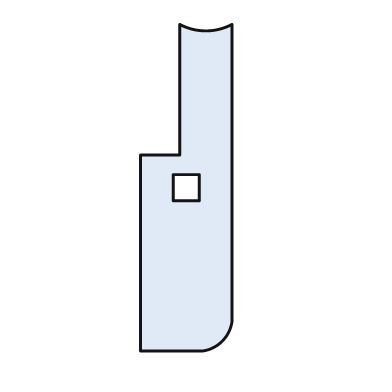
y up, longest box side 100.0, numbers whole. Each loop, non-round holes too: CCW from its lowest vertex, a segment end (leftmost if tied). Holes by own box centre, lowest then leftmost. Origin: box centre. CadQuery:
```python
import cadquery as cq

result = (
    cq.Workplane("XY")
    .moveTo(-14.0, -50.0)
    .lineTo(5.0, -50.0)
    .threePointArc((11.0, -47.0), (14.0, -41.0))
    .lineTo(14.0, 50.0)
    .threePointArc((6.0, 48.0), (-2.0, 50.0))
    .lineTo(-2.0, 10.0)
    .lineTo(-14.0, 10.0)
    .close()
    .moveTo(-4.0, -4.0)
    .lineTo(4.0, -4.0)
    .lineTo(4.0, 4.0)
    .lineTo(-4.0, 4.0)
    .close()
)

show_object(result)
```